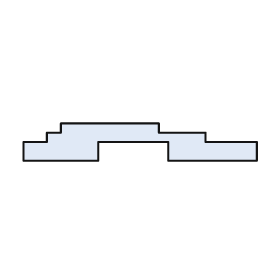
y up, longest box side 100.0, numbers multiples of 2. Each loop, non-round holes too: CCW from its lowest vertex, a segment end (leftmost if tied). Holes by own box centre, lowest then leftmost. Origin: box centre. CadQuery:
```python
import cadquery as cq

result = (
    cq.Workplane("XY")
    .moveTo(-50.0, -8.0)
    .lineTo(-18.0, -8.0)
    .lineTo(-18.0, 0.0)
    .lineTo(12.0, 0.0)
    .lineTo(12.0, -8.0)
    .lineTo(50.0, -8.0)
    .lineTo(50.0, 0.0)
    .lineTo(28.0, 0.0)
    .lineTo(28.0, 4.0)
    .lineTo(8.0, 4.0)
    .lineTo(8.0, 8.0)
    .lineTo(-34.0, 8.0)
    .lineTo(-34.0, 4.0)
    .lineTo(-40.0, 4.0)
    .lineTo(-40.0, 0.0)
    .lineTo(-50.0, 0.0)
    .close()
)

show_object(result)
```